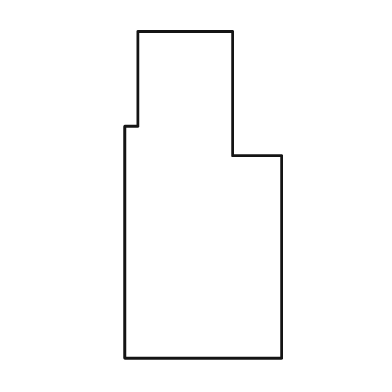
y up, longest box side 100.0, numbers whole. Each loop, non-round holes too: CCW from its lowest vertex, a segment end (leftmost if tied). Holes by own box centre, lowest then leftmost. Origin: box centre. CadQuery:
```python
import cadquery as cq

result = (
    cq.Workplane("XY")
    .moveTo(-24.0, -50.0)
    .lineTo(24.0, -50.0)
    .lineTo(24.0, 12.0)
    .lineTo(9.0, 12.0)
    .lineTo(9.0, 50.0)
    .lineTo(-20.0, 50.0)
    .lineTo(-20.0, 21.0)
    .lineTo(-24.0, 21.0)
    .close()
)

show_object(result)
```